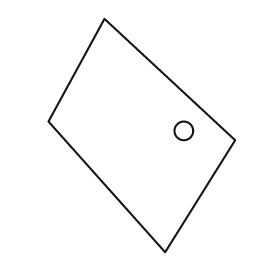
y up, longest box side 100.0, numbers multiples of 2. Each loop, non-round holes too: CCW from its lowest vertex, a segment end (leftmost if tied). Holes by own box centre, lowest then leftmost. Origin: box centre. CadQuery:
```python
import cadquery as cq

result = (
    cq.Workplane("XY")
    .moveTo(10.0, -50.0)
    .lineTo(40.0, -2.0)
    .lineTo(-16.0, 50.0)
    .lineTo(-40.0, 6.0)
    .close()
    .moveTo(18.0, 2.0)
    .circle(4.0)
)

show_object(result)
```